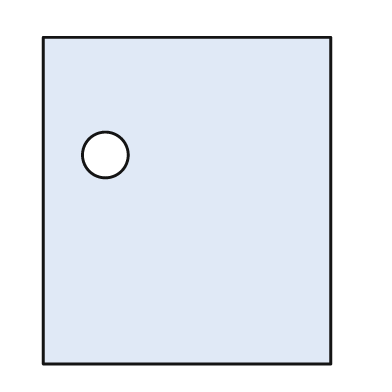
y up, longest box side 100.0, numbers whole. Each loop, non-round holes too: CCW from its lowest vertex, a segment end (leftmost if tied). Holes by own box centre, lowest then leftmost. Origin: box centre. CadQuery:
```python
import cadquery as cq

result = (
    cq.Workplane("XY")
    .moveTo(-44.0, -50.0)
    .lineTo(44.0, -50.0)
    .lineTo(44.0, 50.0)
    .lineTo(-44.0, 50.0)
    .close()
    .moveTo(-25.0, 14.0)
    .circle(7.0)
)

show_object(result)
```